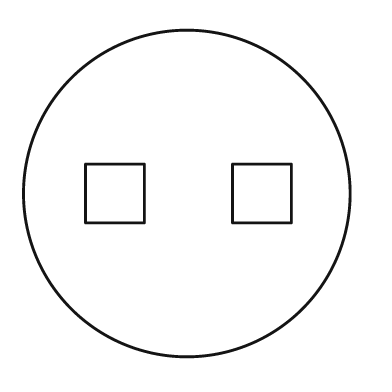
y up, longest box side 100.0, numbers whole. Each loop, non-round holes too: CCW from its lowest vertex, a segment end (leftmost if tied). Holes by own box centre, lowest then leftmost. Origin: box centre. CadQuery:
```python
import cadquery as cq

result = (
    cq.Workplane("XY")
    .moveTo(0.0, 0.0)
    .circle(50.0)
    .moveTo(-31.0, -9.0)
    .lineTo(-13.0, -9.0)
    .lineTo(-13.0, 9.0)
    .lineTo(-31.0, 9.0)
    .close()
    .moveTo(14.0, -9.0)
    .lineTo(32.0, -9.0)
    .lineTo(32.0, 9.0)
    .lineTo(14.0, 9.0)
    .close()
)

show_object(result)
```